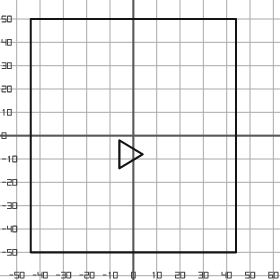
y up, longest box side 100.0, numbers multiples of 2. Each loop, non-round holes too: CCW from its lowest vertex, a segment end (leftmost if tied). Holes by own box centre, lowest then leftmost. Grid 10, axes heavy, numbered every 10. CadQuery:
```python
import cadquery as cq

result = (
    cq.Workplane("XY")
    .moveTo(-44.0, -50.0)
    .lineTo(44.0, -50.0)
    .lineTo(44.0, 50.0)
    .lineTo(-44.0, 50.0)
    .close()
    .moveTo(-6.0, -14.0)
    .lineTo(4.0, -8.0)
    .lineTo(-6.0, -2.0)
    .close()
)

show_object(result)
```